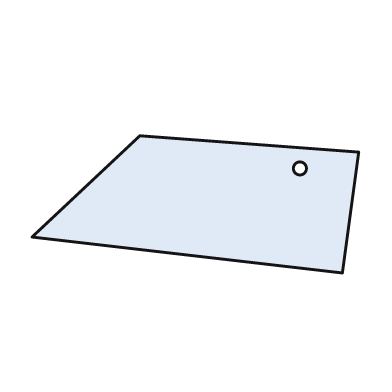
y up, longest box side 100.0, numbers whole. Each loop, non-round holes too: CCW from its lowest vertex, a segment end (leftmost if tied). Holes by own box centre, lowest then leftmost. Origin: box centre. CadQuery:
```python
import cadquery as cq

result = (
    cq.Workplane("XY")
    .moveTo(45.0, -21.0)
    .lineTo(50.0, 16.0)
    .lineTo(-17.0, 21.0)
    .lineTo(-50.0, -10.0)
    .close()
    .moveTo(32.0, 11.0)
    .circle(2.0)
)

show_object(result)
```